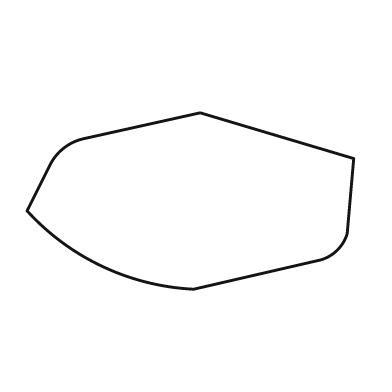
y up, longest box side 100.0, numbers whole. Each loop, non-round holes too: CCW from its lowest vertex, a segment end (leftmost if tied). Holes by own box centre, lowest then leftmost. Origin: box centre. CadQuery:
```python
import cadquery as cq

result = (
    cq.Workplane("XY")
    .moveTo(1.0, -27.0)
    .lineTo(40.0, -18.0)
    .threePointArc((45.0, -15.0), (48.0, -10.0))
    .lineTo(50.0, 13.0)
    .lineTo(3.0, 27.0)
    .lineTo(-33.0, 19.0)
    .threePointArc((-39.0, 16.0), (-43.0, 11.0))
    .lineTo(-50.0, -3.0)
    .threePointArc((-27.0, -20.0), (1.0, -27.0))
    .close()
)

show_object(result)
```